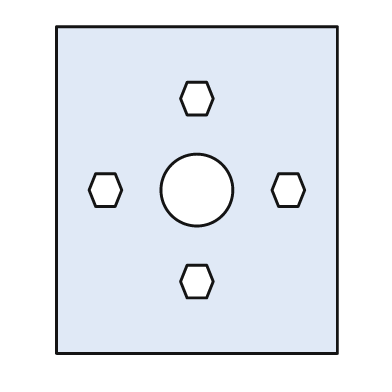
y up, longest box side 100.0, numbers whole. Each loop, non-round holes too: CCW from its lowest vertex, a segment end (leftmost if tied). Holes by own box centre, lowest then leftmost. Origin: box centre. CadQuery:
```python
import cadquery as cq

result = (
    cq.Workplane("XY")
    .moveTo(-43.0, -50.0)
    .lineTo(43.0, -50.0)
    .lineTo(43.0, 50.0)
    .lineTo(-43.0, 50.0)
    .close()
    .moveTo(-3.0, -33.0)
    .lineTo(3.0, -33.0)
    .lineTo(5.0, -28.0)
    .lineTo(3.0, -23.0)
    .lineTo(-3.0, -23.0)
    .lineTo(-5.0, -28.0)
    .close()
    .moveTo(-31.0, -5.0)
    .lineTo(-25.0, -5.0)
    .lineTo(-23.0, 0.0)
    .lineTo(-25.0, 5.0)
    .lineTo(-31.0, 5.0)
    .lineTo(-33.0, 0.0)
    .close()
    .moveTo(0.0, 0.0)
    .circle(11.0)
    .moveTo(25.0, -5.0)
    .lineTo(31.0, -5.0)
    .lineTo(33.0, 0.0)
    .lineTo(31.0, 5.0)
    .lineTo(25.0, 5.0)
    .lineTo(23.0, 0.0)
    .close()
    .moveTo(-3.0, 23.0)
    .lineTo(3.0, 23.0)
    .lineTo(5.0, 28.0)
    .lineTo(3.0, 33.0)
    .lineTo(-3.0, 33.0)
    .lineTo(-5.0, 28.0)
    .close()
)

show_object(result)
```